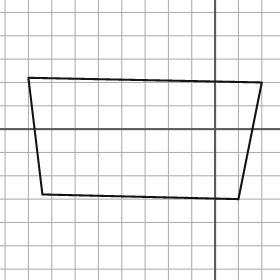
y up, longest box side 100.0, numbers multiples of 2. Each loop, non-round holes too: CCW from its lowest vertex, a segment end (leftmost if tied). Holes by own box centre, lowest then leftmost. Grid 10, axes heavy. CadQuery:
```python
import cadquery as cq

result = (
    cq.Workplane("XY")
    .moveTo(10.0, -30.0)
    .lineTo(20.0, 20.0)
    .lineTo(-80.0, 22.0)
    .lineTo(-74.0, -28.0)
    .close()
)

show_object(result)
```